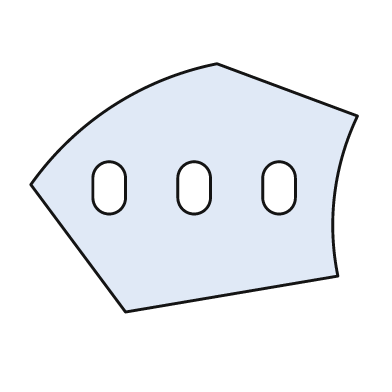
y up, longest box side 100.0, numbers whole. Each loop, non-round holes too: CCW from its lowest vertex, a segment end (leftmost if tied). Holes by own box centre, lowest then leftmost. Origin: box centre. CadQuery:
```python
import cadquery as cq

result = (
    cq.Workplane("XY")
    .moveTo(-21.0, -38.0)
    .lineTo(44.0, -27.0)
    .threePointArc((43.0, -2.0), (50.0, 22.0))
    .lineTo(7.0, 38.0)
    .threePointArc((-25.0, 25.0), (-50.0, 1.0))
    .close()
    .moveTo(-31.0, -3.0)
    .threePointArc((-26.0, -8.0), (-21.0, -3.0))
    .lineTo(-21.0, 3.0)
    .threePointArc((-26.0, 8.0), (-31.0, 3.0))
    .close()
    .moveTo(-5.0, -3.0)
    .threePointArc((0.0, -8.0), (5.0, -3.0))
    .lineTo(5.0, 3.0)
    .threePointArc((0.0, 8.0), (-5.0, 3.0))
    .close()
    .moveTo(21.0, -3.0)
    .threePointArc((26.0, -8.0), (31.0, -3.0))
    .lineTo(31.0, 3.0)
    .threePointArc((26.0, 8.0), (21.0, 3.0))
    .close()
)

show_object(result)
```